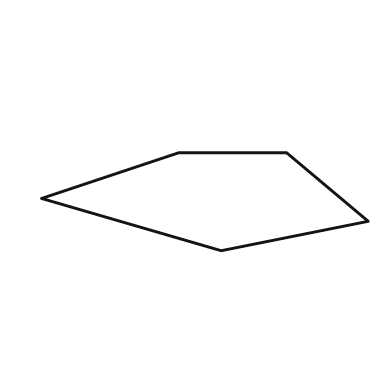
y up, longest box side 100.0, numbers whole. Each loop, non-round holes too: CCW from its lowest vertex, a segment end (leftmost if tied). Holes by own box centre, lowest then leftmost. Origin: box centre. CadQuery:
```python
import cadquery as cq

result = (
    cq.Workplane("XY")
    .moveTo(5.0, -15.0)
    .lineTo(50.0, -6.0)
    .lineTo(25.0, 15.0)
    .lineTo(-8.0, 15.0)
    .lineTo(-50.0, 1.0)
    .close()
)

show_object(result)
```